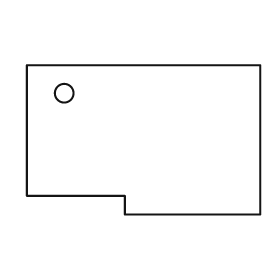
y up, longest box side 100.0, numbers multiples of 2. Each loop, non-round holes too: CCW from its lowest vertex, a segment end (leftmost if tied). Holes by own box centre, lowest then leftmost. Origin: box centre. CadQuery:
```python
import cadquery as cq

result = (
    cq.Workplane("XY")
    .moveTo(-8.0, -32.0)
    .lineTo(50.0, -32.0)
    .lineTo(50.0, 32.0)
    .lineTo(-50.0, 32.0)
    .lineTo(-50.0, -24.0)
    .lineTo(-8.0, -24.0)
    .close()
    .moveTo(-34.0, 20.0)
    .circle(4.0)
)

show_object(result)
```